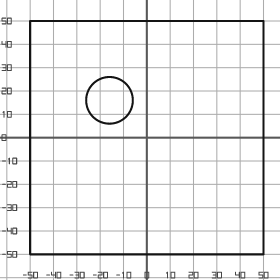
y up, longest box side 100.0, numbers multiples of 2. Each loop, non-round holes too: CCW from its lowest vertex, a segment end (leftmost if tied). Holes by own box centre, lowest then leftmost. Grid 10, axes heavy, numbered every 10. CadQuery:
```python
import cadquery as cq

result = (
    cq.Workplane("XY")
    .moveTo(-50.0, -50.0)
    .lineTo(50.0, -50.0)
    .lineTo(50.0, 50.0)
    .lineTo(-50.0, 50.0)
    .close()
    .moveTo(-16.0, 16.0)
    .circle(10.0)
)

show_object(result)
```